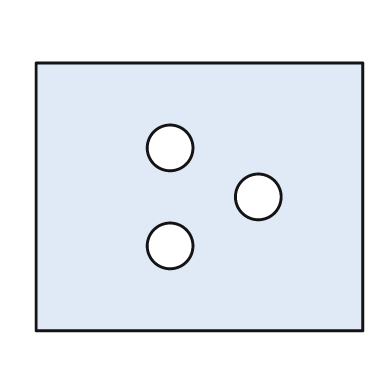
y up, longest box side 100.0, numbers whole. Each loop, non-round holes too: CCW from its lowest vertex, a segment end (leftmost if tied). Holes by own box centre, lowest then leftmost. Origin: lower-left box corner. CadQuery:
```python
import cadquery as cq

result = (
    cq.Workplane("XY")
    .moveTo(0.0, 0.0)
    .lineTo(100.0, 0.0)
    .lineTo(100.0, 82.0)
    .lineTo(0.0, 82.0)
    .close()
    .moveTo(41.0, 26.0)
    .circle(7.0)
    .moveTo(68.0, 41.0)
    .circle(7.0)
    .moveTo(41.0, 56.0)
    .circle(7.0)
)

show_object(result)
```